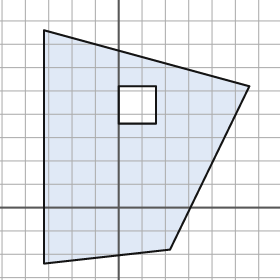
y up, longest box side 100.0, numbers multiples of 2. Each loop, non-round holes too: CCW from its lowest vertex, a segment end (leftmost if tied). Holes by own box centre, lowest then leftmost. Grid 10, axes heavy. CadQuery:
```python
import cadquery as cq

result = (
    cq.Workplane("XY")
    .moveTo(-32.0, -24.0)
    .lineTo(22.0, -18.0)
    .lineTo(56.0, 52.0)
    .lineTo(-32.0, 76.0)
    .close()
    .moveTo(0.0, 36.0)
    .lineTo(16.0, 36.0)
    .lineTo(16.0, 52.0)
    .lineTo(0.0, 52.0)
    .close()
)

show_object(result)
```